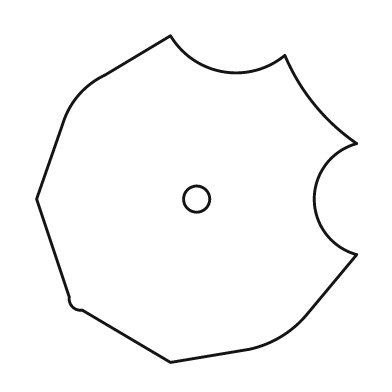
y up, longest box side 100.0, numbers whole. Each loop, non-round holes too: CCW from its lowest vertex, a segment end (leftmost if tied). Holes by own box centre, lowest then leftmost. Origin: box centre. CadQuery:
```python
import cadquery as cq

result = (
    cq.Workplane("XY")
    .moveTo(-8.0, -50.0)
    .lineTo(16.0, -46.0)
    .threePointArc((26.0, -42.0), (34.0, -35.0))
    .lineTo(49.0, -17.0)
    .threePointArc((36.0, 0.0), (49.0, 17.0))
    .threePointArc((36.0, 29.0), (27.0, 44.0))
    .threePointArc((8.0, 39.0), (-8.0, 50.0))
    .lineTo(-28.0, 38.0)
    .threePointArc((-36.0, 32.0), (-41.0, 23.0))
    .lineTo(-49.0, 0.0)
    .lineTo(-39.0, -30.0)
    .threePointArc((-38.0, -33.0), (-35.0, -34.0))
    .close()
    .moveTo(0.0, 0.0)
    .circle(4.0)
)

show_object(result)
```